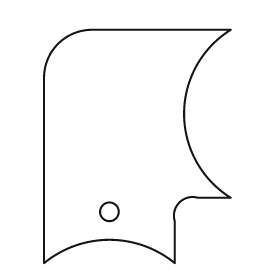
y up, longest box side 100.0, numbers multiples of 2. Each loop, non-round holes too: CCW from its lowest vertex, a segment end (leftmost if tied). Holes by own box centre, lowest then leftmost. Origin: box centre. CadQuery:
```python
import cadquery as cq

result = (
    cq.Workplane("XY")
    .moveTo(-40.0, -50.0)
    .threePointArc((-12.0, -40.0), (16.0, -50.0))
    .lineTo(16.0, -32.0)
    .threePointArc((18.0, -24.0), (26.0, -22.0))
    .lineTo(40.0, -22.0)
    .threePointArc((20.0, 14.0), (40.0, 50.0))
    .lineTo(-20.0, 50.0)
    .threePointArc((-34.0, 44.0), (-40.0, 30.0))
    .close()
    .moveTo(-12.0, -28.0)
    .circle(4.0)
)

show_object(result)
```